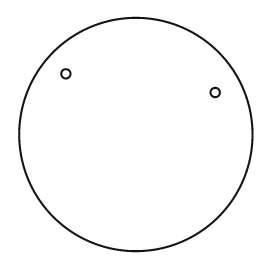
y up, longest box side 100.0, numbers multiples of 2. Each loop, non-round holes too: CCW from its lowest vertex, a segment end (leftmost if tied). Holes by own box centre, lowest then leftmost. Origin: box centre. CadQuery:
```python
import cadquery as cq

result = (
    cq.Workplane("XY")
    .moveTo(0.0, 0.0)
    .circle(50.0)
    .moveTo(34.0, 18.0)
    .circle(2.0)
    .moveTo(-30.0, 26.0)
    .circle(2.0)
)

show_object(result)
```